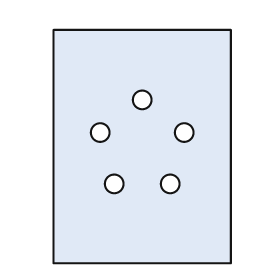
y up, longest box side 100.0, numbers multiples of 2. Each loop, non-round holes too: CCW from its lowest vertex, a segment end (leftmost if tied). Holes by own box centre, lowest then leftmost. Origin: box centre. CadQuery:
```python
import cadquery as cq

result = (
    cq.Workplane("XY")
    .moveTo(-38.0, -50.0)
    .lineTo(38.0, -50.0)
    .lineTo(38.0, 50.0)
    .lineTo(-38.0, 50.0)
    .close()
    .moveTo(-12.0, -16.0)
    .circle(4.0)
    .moveTo(12.0, -16.0)
    .circle(4.0)
    .moveTo(-18.0, 6.0)
    .circle(4.0)
    .moveTo(18.0, 6.0)
    .circle(4.0)
    .moveTo(0.0, 20.0)
    .circle(4.0)
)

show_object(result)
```